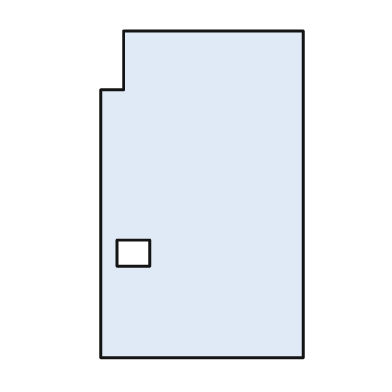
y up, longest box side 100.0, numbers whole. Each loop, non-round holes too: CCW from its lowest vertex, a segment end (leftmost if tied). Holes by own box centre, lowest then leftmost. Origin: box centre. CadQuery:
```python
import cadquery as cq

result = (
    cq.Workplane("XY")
    .moveTo(-31.0, -50.0)
    .lineTo(31.0, -50.0)
    .lineTo(31.0, 50.0)
    .lineTo(-24.0, 50.0)
    .lineTo(-24.0, 32.0)
    .lineTo(-31.0, 32.0)
    .close()
    .moveTo(-26.0, -22.0)
    .lineTo(-16.0, -22.0)
    .lineTo(-16.0, -14.0)
    .lineTo(-26.0, -14.0)
    .close()
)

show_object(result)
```